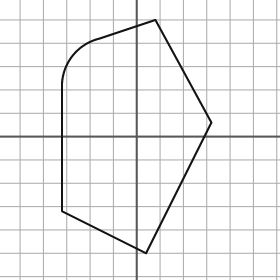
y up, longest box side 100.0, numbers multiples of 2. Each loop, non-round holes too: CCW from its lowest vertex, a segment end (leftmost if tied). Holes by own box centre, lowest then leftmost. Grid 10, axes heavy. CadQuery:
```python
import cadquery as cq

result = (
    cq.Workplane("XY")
    .moveTo(4.0, -50.0)
    .lineTo(32.0, 6.0)
    .lineTo(8.0, 50.0)
    .lineTo(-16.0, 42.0)
    .threePointArc((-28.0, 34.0), (-32.0, 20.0))
    .lineTo(-32.0, -32.0)
    .close()
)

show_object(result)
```